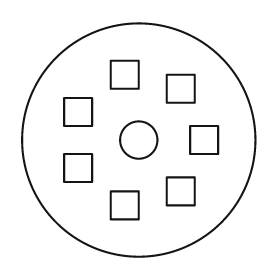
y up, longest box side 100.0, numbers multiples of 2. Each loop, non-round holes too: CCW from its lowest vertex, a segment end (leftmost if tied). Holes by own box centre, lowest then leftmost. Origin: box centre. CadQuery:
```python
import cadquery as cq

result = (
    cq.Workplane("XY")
    .moveTo(0.0, 0.0)
    .circle(50.0)
    .moveTo(-12.0, -34.0)
    .lineTo(0.0, -34.0)
    .lineTo(0.0, -22.0)
    .lineTo(-12.0, -22.0)
    .close()
    .moveTo(12.0, -28.0)
    .lineTo(24.0, -28.0)
    .lineTo(24.0, -16.0)
    .lineTo(12.0, -16.0)
    .close()
    .moveTo(-32.0, -18.0)
    .lineTo(-20.0, -18.0)
    .lineTo(-20.0, -6.0)
    .lineTo(-32.0, -6.0)
    .close()
    .moveTo(0.0, 0.0)
    .circle(8.0)
    .moveTo(22.0, -6.0)
    .lineTo(34.0, -6.0)
    .lineTo(34.0, 6.0)
    .lineTo(22.0, 6.0)
    .close()
    .moveTo(-32.0, 6.0)
    .lineTo(-20.0, 6.0)
    .lineTo(-20.0, 18.0)
    .lineTo(-32.0, 18.0)
    .close()
    .moveTo(12.0, 16.0)
    .lineTo(24.0, 16.0)
    .lineTo(24.0, 28.0)
    .lineTo(12.0, 28.0)
    .close()
    .moveTo(-12.0, 22.0)
    .lineTo(0.0, 22.0)
    .lineTo(0.0, 34.0)
    .lineTo(-12.0, 34.0)
    .close()
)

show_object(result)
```